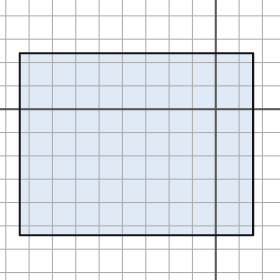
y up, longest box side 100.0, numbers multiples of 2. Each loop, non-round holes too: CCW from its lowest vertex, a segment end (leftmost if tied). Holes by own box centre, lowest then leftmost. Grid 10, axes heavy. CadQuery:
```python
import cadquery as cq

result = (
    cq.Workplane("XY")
    .moveTo(-84.0, -54.0)
    .lineTo(16.0, -54.0)
    .lineTo(16.0, 24.0)
    .lineTo(-84.0, 24.0)
    .close()
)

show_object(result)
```